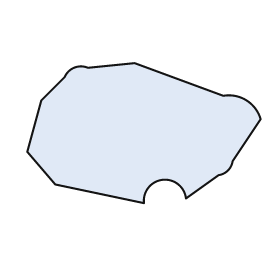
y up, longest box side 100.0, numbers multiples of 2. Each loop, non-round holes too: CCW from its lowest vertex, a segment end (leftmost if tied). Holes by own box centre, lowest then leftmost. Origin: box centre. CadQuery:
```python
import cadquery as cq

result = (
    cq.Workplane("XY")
    .moveTo(0.0, -30.0)
    .threePointArc((8.0, -20.0), (18.0, -28.0))
    .lineTo(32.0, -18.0)
    .threePointArc((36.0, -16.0), (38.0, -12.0))
    .lineTo(50.0, 6.0)
    .threePointArc((44.0, 14.0), (34.0, 16.0))
    .lineTo(-4.0, 30.0)
    .lineTo(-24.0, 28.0)
    .threePointArc((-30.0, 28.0), (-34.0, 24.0))
    .lineTo(-44.0, 14.0)
    .lineTo(-50.0, -8.0)
    .lineTo(-38.0, -22.0)
    .close()
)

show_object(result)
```